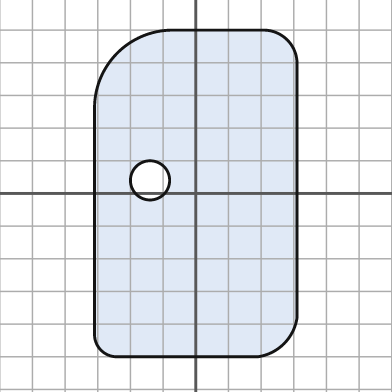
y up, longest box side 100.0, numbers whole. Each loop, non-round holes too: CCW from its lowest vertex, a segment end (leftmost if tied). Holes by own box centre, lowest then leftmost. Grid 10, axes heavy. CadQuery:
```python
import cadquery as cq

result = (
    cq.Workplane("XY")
    .moveTo(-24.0, -50.0)
    .lineTo(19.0, -50.0)
    .threePointArc((27.0, -46.0), (31.0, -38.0))
    .lineTo(31.0, 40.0)
    .threePointArc((28.0, 47.0), (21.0, 50.0))
    .lineTo(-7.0, 50.0)
    .threePointArc((-24.0, 43.0), (-31.0, 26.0))
    .lineTo(-31.0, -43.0)
    .threePointArc((-29.0, -48.0), (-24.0, -50.0))
    .close()
    .moveTo(-14.0, 4.0)
    .circle(6.0)
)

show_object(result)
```